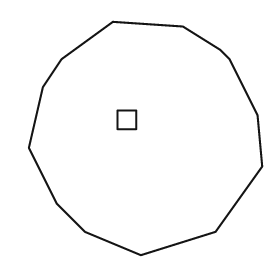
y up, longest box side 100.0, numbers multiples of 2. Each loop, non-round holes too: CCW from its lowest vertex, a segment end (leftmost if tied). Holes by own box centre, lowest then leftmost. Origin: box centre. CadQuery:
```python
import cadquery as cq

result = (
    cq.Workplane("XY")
    .moveTo(-2.0, -50.0)
    .lineTo(30.0, -40.0)
    .lineTo(50.0, -12.0)
    .lineTo(48.0, 10.0)
    .lineTo(36.0, 34.0)
    .lineTo(32.0, 38.0)
    .lineTo(16.0, 48.0)
    .lineTo(-14.0, 50.0)
    .lineTo(-36.0, 34.0)
    .lineTo(-44.0, 22.0)
    .lineTo(-50.0, -4.0)
    .lineTo(-38.0, -28.0)
    .lineTo(-26.0, -40.0)
    .close()
    .moveTo(-12.0, 4.0)
    .lineTo(-4.0, 4.0)
    .lineTo(-4.0, 12.0)
    .lineTo(-12.0, 12.0)
    .close()
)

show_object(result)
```